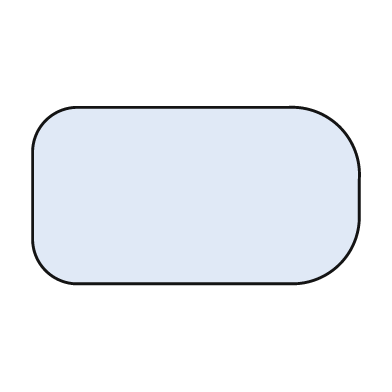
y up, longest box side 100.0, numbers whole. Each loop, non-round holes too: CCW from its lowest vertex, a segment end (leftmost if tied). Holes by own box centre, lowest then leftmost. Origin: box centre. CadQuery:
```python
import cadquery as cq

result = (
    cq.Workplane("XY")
    .moveTo(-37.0, -27.0)
    .lineTo(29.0, -27.0)
    .threePointArc((44.0, -21.0), (50.0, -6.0))
    .lineTo(50.0, 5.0)
    .threePointArc((44.0, 21.0), (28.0, 27.0))
    .lineTo(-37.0, 27.0)
    .threePointArc((-46.0, 23.0), (-50.0, 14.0))
    .lineTo(-50.0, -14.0)
    .threePointArc((-46.0, -23.0), (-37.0, -27.0))
    .close()
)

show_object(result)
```